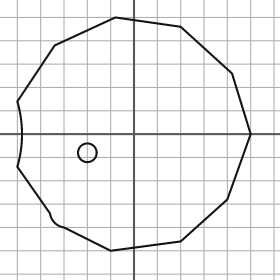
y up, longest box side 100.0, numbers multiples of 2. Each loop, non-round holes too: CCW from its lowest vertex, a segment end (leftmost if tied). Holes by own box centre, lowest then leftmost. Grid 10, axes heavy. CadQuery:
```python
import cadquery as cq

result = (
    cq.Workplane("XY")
    .moveTo(-10.0, -50.0)
    .lineTo(20.0, -46.0)
    .lineTo(40.0, -28.0)
    .lineTo(50.0, 0.0)
    .lineTo(42.0, 26.0)
    .lineTo(20.0, 46.0)
    .lineTo(-8.0, 50.0)
    .lineTo(-34.0, 38.0)
    .lineTo(-50.0, 14.0)
    .threePointArc((-48.0, 0.0), (-50.0, -14.0))
    .lineTo(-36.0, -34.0)
    .threePointArc((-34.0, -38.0), (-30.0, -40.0))
    .close()
    .moveTo(-20.0, -8.0)
    .circle(4.0)
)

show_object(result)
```